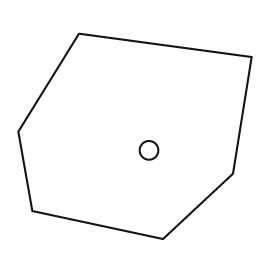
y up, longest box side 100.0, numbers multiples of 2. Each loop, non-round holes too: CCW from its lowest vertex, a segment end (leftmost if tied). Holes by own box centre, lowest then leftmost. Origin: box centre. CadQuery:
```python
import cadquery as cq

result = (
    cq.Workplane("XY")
    .moveTo(12.0, -44.0)
    .lineTo(42.0, -16.0)
    .lineTo(50.0, 34.0)
    .lineTo(-24.0, 44.0)
    .lineTo(-50.0, 2.0)
    .lineTo(-44.0, -32.0)
    .close()
    .moveTo(6.0, -6.0)
    .circle(4.0)
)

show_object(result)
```